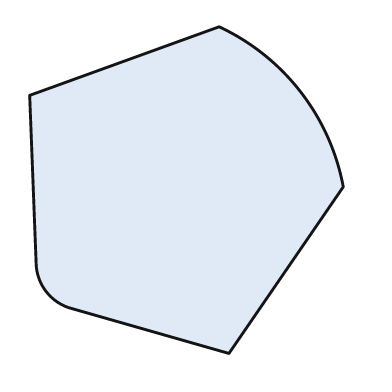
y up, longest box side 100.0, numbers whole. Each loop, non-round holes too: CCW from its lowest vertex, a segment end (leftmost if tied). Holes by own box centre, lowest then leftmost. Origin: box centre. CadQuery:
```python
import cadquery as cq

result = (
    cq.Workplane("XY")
    .moveTo(13.0, -50.0)
    .lineTo(48.0, 1.0)
    .threePointArc((35.0, 30.0), (10.0, 50.0))
    .lineTo(-48.0, 29.0)
    .lineTo(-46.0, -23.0)
    .threePointArc((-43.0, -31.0), (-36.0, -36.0))
    .close()
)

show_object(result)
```